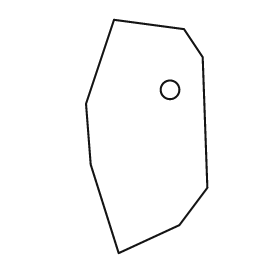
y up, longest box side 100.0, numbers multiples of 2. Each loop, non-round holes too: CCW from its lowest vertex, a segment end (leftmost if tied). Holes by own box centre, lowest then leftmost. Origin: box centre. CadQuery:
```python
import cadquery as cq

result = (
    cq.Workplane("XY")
    .moveTo(-12.0, -50.0)
    .lineTo(14.0, -38.0)
    .lineTo(26.0, -22.0)
    .lineTo(24.0, 34.0)
    .lineTo(16.0, 46.0)
    .lineTo(-14.0, 50.0)
    .lineTo(-26.0, 14.0)
    .lineTo(-24.0, -12.0)
    .close()
    .moveTo(10.0, 20.0)
    .circle(4.0)
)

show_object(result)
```